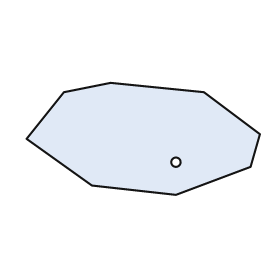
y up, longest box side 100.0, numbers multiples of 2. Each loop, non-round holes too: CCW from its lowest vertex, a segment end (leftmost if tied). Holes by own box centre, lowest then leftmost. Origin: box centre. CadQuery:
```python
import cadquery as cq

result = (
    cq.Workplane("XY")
    .moveTo(14.0, -24.0)
    .lineTo(46.0, -12.0)
    .lineTo(50.0, 2.0)
    .lineTo(26.0, 20.0)
    .lineTo(-14.0, 24.0)
    .lineTo(-34.0, 20.0)
    .lineTo(-50.0, 0.0)
    .lineTo(-22.0, -20.0)
    .close()
    .moveTo(14.0, -10.0)
    .circle(2.0)
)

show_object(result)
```